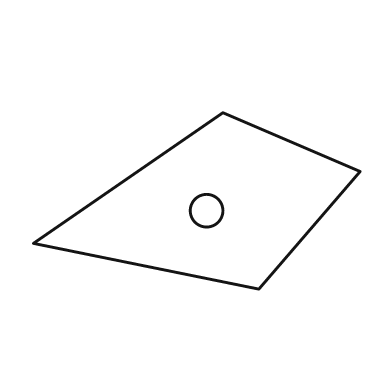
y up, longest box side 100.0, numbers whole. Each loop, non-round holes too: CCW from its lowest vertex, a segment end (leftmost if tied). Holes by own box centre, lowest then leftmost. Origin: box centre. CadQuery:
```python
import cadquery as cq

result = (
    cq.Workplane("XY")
    .moveTo(19.0, -27.0)
    .lineTo(50.0, 9.0)
    .lineTo(8.0, 27.0)
    .lineTo(-50.0, -13.0)
    .close()
    .moveTo(3.0, -3.0)
    .circle(5.0)
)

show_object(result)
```